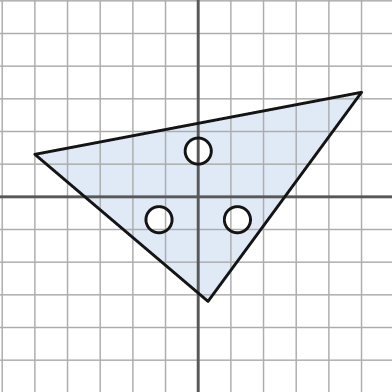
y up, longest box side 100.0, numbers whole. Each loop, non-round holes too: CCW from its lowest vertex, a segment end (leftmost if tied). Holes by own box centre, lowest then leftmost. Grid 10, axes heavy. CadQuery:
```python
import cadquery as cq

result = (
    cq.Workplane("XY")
    .moveTo(3.0, -32.0)
    .lineTo(50.0, 32.0)
    .lineTo(-50.0, 13.0)
    .close()
    .moveTo(-12.0, -7.0)
    .circle(4.0)
    .moveTo(12.0, -7.0)
    .circle(4.0)
    .moveTo(0.0, 14.0)
    .circle(4.0)
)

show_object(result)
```